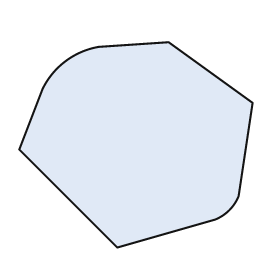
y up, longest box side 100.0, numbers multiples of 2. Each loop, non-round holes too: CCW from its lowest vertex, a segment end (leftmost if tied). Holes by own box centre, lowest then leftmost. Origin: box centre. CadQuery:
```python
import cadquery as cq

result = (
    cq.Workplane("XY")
    .moveTo(-8.0, -44.0)
    .lineTo(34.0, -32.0)
    .threePointArc((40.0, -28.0), (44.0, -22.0))
    .lineTo(50.0, 18.0)
    .lineTo(14.0, 44.0)
    .lineTo(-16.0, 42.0)
    .threePointArc((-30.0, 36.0), (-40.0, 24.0))
    .lineTo(-50.0, -2.0)
    .close()
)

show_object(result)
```